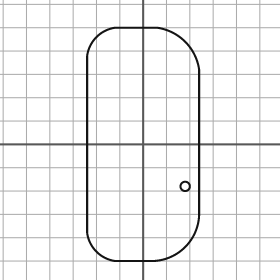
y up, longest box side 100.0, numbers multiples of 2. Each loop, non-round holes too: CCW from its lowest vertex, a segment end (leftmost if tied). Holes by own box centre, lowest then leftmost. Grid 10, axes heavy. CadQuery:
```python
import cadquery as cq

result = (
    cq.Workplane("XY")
    .moveTo(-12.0, -50.0)
    .lineTo(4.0, -50.0)
    .threePointArc((18.0, -44.0), (24.0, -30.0))
    .lineTo(24.0, 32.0)
    .threePointArc((18.0, 44.0), (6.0, 50.0))
    .lineTo(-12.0, 50.0)
    .threePointArc((-20.0, 46.0), (-24.0, 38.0))
    .lineTo(-24.0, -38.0)
    .threePointArc((-20.0, -46.0), (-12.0, -50.0))
    .close()
    .moveTo(18.0, -18.0)
    .circle(2.0)
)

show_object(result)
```